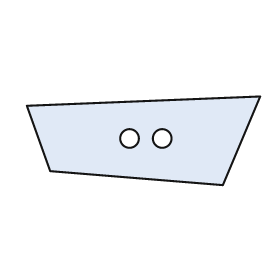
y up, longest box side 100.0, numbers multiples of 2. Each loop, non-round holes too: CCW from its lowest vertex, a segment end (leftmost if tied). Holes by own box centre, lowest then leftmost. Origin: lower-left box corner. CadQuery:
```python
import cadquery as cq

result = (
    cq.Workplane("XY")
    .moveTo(84.0, 0.0)
    .lineTo(100.0, 38.0)
    .lineTo(0.0, 34.0)
    .lineTo(10.0, 6.0)
    .close()
    .moveTo(44.0, 20.0)
    .circle(4.0)
    .moveTo(58.0, 20.0)
    .circle(4.0)
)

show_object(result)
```